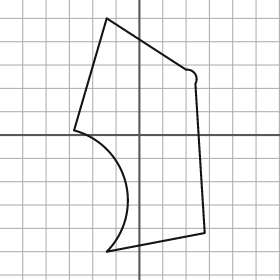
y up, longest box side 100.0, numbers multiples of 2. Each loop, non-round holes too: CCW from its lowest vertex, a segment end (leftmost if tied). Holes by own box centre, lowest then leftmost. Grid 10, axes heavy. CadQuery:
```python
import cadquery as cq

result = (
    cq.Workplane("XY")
    .moveTo(-14.0, -50.0)
    .lineTo(28.0, -42.0)
    .lineTo(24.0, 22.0)
    .threePointArc((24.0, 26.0), (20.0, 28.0))
    .lineTo(-14.0, 50.0)
    .lineTo(-28.0, 2.0)
    .threePointArc((-6.0, -20.0), (-14.0, -50.0))
    .close()
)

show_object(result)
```